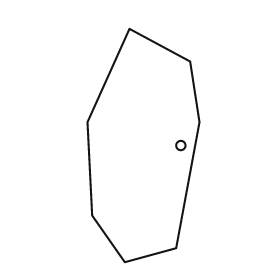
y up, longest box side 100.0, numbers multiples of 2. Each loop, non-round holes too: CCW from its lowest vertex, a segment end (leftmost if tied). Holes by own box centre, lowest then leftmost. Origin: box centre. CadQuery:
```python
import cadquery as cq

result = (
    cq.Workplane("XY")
    .moveTo(-8.0, -50.0)
    .lineTo(14.0, -44.0)
    .lineTo(24.0, 10.0)
    .lineTo(20.0, 36.0)
    .lineTo(-6.0, 50.0)
    .lineTo(-24.0, 10.0)
    .lineTo(-22.0, -30.0)
    .close()
    .moveTo(16.0, 0.0)
    .circle(2.0)
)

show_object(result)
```